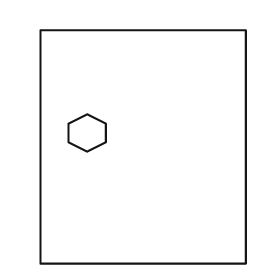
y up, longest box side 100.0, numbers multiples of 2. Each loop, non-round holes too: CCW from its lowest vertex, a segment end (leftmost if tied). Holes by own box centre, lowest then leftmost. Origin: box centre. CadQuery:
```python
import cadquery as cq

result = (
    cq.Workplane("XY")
    .moveTo(-44.0, -50.0)
    .lineTo(44.0, -50.0)
    .lineTo(44.0, 50.0)
    .lineTo(-44.0, 50.0)
    .close()
    .moveTo(-24.0, -2.0)
    .lineTo(-16.0, 2.0)
    .lineTo(-16.0, 10.0)
    .lineTo(-24.0, 14.0)
    .lineTo(-32.0, 10.0)
    .lineTo(-32.0, 2.0)
    .close()
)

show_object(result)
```